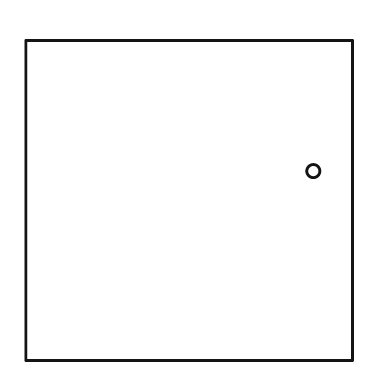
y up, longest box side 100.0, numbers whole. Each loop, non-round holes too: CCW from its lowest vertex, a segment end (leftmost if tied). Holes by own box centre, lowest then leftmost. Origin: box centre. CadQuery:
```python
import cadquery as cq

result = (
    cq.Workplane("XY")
    .moveTo(-50.0, -49.0)
    .lineTo(50.0, -49.0)
    .lineTo(50.0, 49.0)
    .lineTo(-50.0, 49.0)
    .close()
    .moveTo(38.0, 9.0)
    .circle(2.0)
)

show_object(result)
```